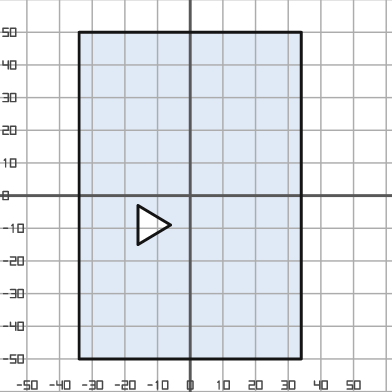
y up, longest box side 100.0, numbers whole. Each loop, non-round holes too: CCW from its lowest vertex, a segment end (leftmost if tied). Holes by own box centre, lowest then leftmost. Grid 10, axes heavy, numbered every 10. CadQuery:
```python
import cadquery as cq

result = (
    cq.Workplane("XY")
    .moveTo(-34.0, -50.0)
    .lineTo(34.0, -50.0)
    .lineTo(34.0, 50.0)
    .lineTo(-34.0, 50.0)
    .close()
    .moveTo(-16.0, -15.0)
    .lineTo(-6.0, -9.0)
    .lineTo(-16.0, -3.0)
    .close()
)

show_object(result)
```